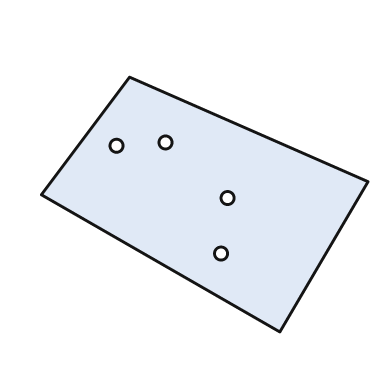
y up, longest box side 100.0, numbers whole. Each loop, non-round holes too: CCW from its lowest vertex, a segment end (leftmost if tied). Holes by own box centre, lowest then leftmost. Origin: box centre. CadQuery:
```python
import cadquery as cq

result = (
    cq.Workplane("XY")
    .moveTo(23.0, -39.0)
    .lineTo(50.0, 7.0)
    .lineTo(-23.0, 39.0)
    .lineTo(-50.0, 3.0)
    .close()
    .moveTo(5.0, -15.0)
    .circle(2.0)
    .moveTo(7.0, 2.0)
    .circle(2.0)
    .moveTo(-27.0, 18.0)
    .circle(2.0)
    .moveTo(-12.0, 19.0)
    .circle(2.0)
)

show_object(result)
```